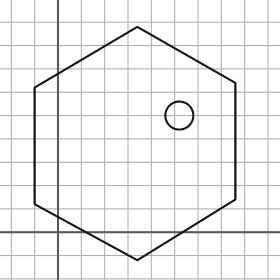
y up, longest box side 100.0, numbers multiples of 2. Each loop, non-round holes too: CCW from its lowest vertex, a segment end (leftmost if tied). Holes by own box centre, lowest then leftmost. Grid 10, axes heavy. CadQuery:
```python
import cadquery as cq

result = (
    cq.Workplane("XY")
    .moveTo(34.0, -12.0)
    .lineTo(76.0, 14.0)
    .lineTo(76.0, 64.0)
    .lineTo(34.0, 88.0)
    .lineTo(-10.0, 62.0)
    .lineTo(-10.0, 12.0)
    .close()
    .moveTo(52.0, 50.0)
    .circle(6.0)
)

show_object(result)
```